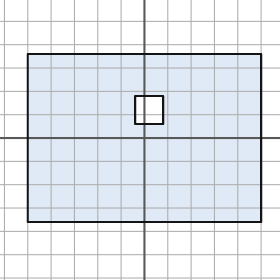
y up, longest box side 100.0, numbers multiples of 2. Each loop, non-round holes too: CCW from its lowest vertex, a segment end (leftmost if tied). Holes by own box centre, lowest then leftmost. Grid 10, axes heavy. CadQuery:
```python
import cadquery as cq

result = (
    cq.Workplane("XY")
    .moveTo(-50.0, -36.0)
    .lineTo(50.0, -36.0)
    .lineTo(50.0, 36.0)
    .lineTo(-50.0, 36.0)
    .close()
    .moveTo(-4.0, 6.0)
    .lineTo(8.0, 6.0)
    .lineTo(8.0, 18.0)
    .lineTo(-4.0, 18.0)
    .close()
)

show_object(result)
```